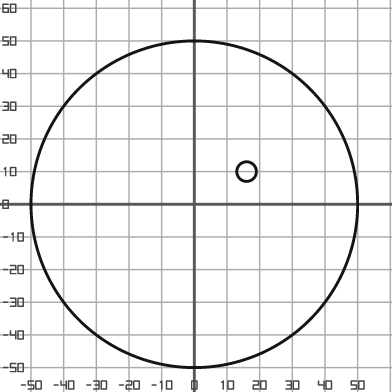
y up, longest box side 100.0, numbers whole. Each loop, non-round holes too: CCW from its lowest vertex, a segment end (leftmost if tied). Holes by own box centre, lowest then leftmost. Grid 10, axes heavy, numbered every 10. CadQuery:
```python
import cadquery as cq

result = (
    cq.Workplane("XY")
    .moveTo(0.0, 0.0)
    .circle(50.0)
    .moveTo(16.0, 10.0)
    .circle(3.0)
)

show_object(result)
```